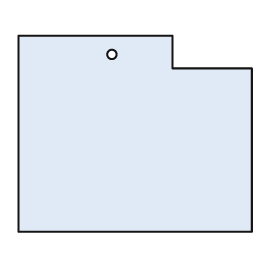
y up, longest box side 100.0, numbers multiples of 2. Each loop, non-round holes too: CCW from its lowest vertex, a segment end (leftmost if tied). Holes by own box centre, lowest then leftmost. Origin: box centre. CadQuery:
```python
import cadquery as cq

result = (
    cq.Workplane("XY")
    .moveTo(-50.0, -42.0)
    .lineTo(50.0, -42.0)
    .lineTo(50.0, 28.0)
    .lineTo(16.0, 28.0)
    .lineTo(16.0, 42.0)
    .lineTo(-50.0, 42.0)
    .close()
    .moveTo(-10.0, 34.0)
    .circle(2.0)
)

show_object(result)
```